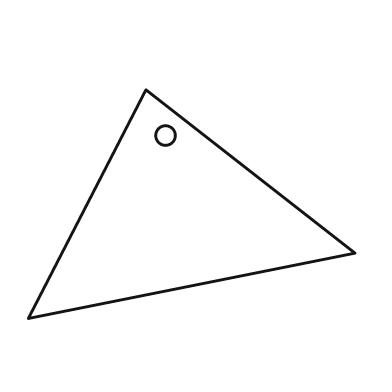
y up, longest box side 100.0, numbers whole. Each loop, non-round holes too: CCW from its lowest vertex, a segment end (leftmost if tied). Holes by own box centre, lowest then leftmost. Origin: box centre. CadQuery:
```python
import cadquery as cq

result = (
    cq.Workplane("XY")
    .moveTo(-50.0, -35.0)
    .lineTo(50.0, -15.0)
    .lineTo(-14.0, 35.0)
    .close()
    .moveTo(-8.0, 21.0)
    .circle(3.0)
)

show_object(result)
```